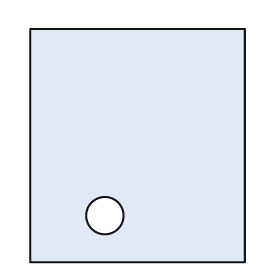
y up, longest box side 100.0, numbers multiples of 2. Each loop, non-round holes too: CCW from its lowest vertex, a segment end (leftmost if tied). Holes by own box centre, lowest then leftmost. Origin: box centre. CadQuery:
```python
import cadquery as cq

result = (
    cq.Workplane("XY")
    .moveTo(-46.0, -50.0)
    .lineTo(46.0, -50.0)
    .lineTo(46.0, 50.0)
    .lineTo(-46.0, 50.0)
    .close()
    .moveTo(-14.0, -30.0)
    .circle(8.0)
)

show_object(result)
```